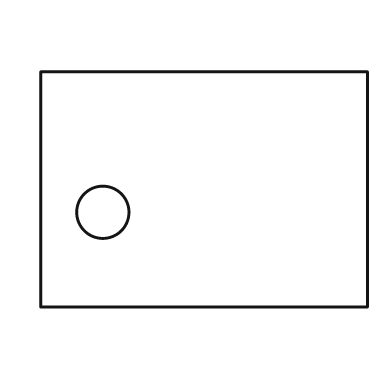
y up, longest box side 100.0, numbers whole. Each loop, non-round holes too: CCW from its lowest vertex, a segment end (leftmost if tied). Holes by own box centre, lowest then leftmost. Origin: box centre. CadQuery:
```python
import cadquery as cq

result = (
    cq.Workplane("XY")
    .moveTo(-50.0, -36.0)
    .lineTo(50.0, -36.0)
    .lineTo(50.0, 36.0)
    .lineTo(-50.0, 36.0)
    .close()
    .moveTo(-31.0, -7.0)
    .circle(8.0)
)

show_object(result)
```